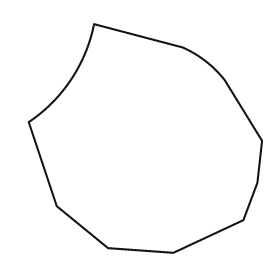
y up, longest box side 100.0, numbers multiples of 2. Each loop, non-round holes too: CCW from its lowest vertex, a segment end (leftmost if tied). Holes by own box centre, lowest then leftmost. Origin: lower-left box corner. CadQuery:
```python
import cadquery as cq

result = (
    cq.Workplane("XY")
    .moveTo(62.0, 0.0)
    .lineTo(92.0, 14.0)
    .lineTo(98.0, 30.0)
    .lineTo(100.0, 48.0)
    .lineTo(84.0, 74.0)
    .threePointArc((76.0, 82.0), (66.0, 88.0))
    .lineTo(28.0, 98.0)
    .threePointArc((18.0, 74.0), (0.0, 56.0))
    .lineTo(12.0, 20.0)
    .lineTo(34.0, 2.0)
    .close()
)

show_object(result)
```